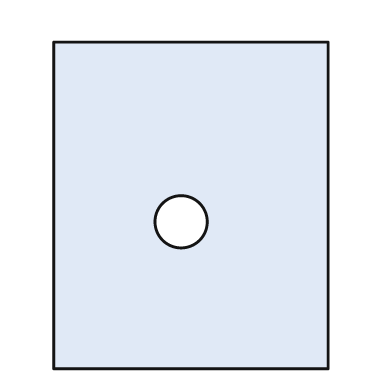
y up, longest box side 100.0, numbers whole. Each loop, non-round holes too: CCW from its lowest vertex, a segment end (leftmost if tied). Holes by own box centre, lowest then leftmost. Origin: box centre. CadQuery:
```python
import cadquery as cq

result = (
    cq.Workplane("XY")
    .moveTo(-42.0, -50.0)
    .lineTo(42.0, -50.0)
    .lineTo(42.0, 50.0)
    .lineTo(-42.0, 50.0)
    .close()
    .moveTo(-3.0, -5.0)
    .circle(8.0)
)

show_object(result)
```